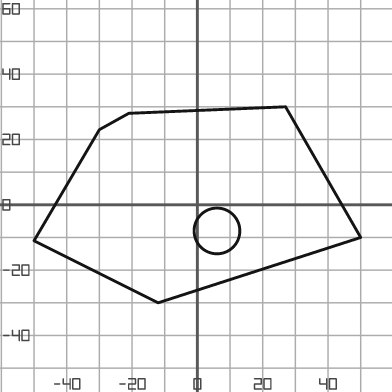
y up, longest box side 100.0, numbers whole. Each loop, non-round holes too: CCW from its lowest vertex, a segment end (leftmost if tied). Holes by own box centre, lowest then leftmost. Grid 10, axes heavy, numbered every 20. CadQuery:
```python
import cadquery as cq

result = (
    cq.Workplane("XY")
    .moveTo(-12.0, -30.0)
    .lineTo(50.0, -10.0)
    .lineTo(27.0, 30.0)
    .lineTo(-21.0, 28.0)
    .lineTo(-30.0, 23.0)
    .lineTo(-50.0, -11.0)
    .close()
    .moveTo(6.0, -8.0)
    .circle(7.0)
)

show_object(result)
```